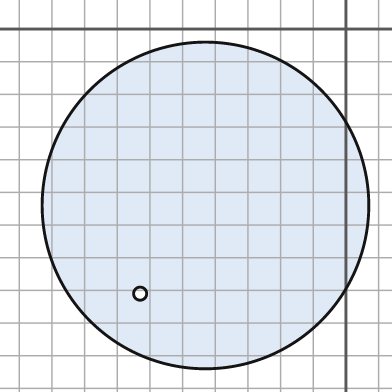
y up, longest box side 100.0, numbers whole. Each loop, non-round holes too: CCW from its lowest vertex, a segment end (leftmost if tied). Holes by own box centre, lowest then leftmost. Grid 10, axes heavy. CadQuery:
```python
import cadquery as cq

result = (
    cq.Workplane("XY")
    .moveTo(-43.0, -54.0)
    .circle(50.0)
    .moveTo(-63.0, -81.0)
    .circle(2.0)
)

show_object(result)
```